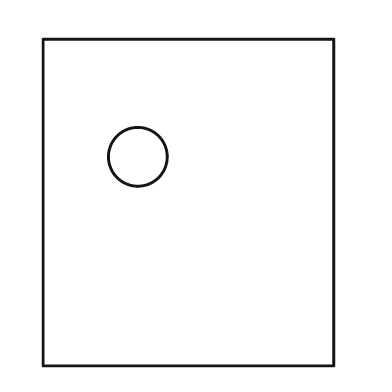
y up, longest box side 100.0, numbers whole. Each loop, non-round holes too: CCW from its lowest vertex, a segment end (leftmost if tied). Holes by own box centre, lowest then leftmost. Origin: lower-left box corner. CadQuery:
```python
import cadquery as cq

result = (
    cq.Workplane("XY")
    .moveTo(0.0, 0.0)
    .lineTo(89.0, 0.0)
    .lineTo(89.0, 100.0)
    .lineTo(0.0, 100.0)
    .close()
    .moveTo(29.0, 64.0)
    .circle(9.0)
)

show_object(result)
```